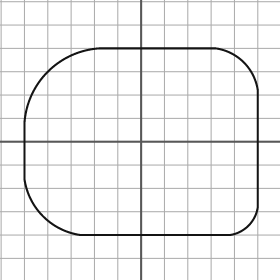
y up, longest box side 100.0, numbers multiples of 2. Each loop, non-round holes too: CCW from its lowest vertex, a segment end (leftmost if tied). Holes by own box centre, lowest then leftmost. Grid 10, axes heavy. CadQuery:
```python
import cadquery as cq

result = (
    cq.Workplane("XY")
    .moveTo(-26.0, -40.0)
    .lineTo(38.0, -40.0)
    .threePointArc((46.0, -36.0), (50.0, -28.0))
    .lineTo(50.0, 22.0)
    .threePointArc((44.0, 34.0), (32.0, 40.0))
    .lineTo(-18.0, 40.0)
    .threePointArc((-40.0, 30.0), (-50.0, 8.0))
    .lineTo(-50.0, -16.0)
    .threePointArc((-42.0, -32.0), (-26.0, -40.0))
    .close()
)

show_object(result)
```